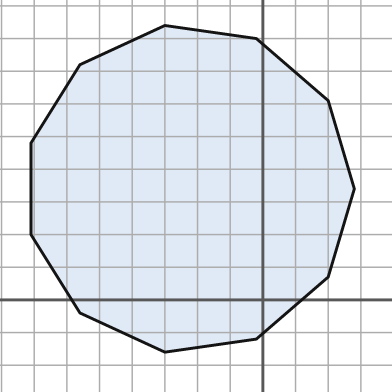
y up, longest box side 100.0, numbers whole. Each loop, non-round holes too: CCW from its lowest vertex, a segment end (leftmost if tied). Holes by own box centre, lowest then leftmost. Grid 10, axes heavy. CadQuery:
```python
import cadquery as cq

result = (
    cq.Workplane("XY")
    .moveTo(-30.0, -16.0)
    .lineTo(-2.0, -12.0)
    .lineTo(20.0, 7.0)
    .lineTo(28.0, 34.0)
    .lineTo(20.0, 61.0)
    .lineTo(-2.0, 80.0)
    .lineTo(-30.0, 84.0)
    .lineTo(-56.0, 72.0)
    .lineTo(-71.0, 48.0)
    .lineTo(-71.0, 20.0)
    .lineTo(-56.0, -4.0)
    .close()
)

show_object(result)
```